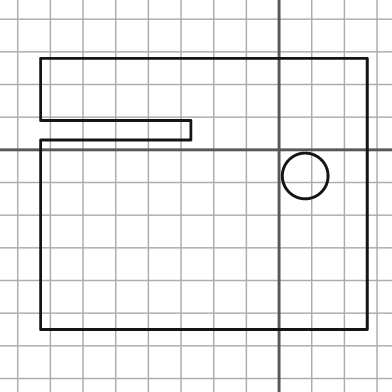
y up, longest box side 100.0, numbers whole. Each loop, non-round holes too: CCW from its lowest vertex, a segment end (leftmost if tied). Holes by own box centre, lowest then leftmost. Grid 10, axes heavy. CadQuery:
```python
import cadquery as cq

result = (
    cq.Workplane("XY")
    .moveTo(-73.0, -55.0)
    .lineTo(27.0, -55.0)
    .lineTo(27.0, 28.0)
    .lineTo(-73.0, 28.0)
    .lineTo(-73.0, 9.0)
    .lineTo(-27.0, 9.0)
    .lineTo(-27.0, 3.0)
    .lineTo(-73.0, 3.0)
    .close()
    .moveTo(8.0, -8.0)
    .circle(7.0)
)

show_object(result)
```